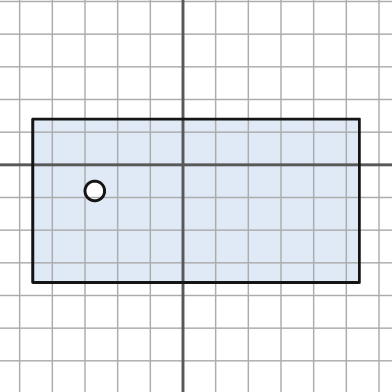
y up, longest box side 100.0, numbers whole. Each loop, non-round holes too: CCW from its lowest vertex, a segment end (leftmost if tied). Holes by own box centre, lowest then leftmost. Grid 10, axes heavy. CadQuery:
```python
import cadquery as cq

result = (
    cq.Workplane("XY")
    .moveTo(-46.0, -36.0)
    .lineTo(54.0, -36.0)
    .lineTo(54.0, 14.0)
    .lineTo(-46.0, 14.0)
    .close()
    .moveTo(-27.0, -8.0)
    .circle(3.0)
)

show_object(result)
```